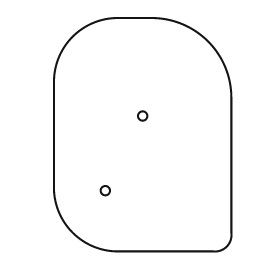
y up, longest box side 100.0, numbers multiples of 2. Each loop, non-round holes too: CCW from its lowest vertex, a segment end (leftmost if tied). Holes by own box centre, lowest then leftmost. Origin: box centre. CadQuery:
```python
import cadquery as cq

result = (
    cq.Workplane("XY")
    .moveTo(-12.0, -50.0)
    .lineTo(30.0, -50.0)
    .threePointArc((36.0, -48.0), (38.0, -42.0))
    .lineTo(38.0, 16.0)
    .threePointArc((28.0, 40.0), (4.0, 50.0))
    .lineTo(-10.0, 50.0)
    .threePointArc((-30.0, 42.0), (-38.0, 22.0))
    .lineTo(-38.0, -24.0)
    .threePointArc((-30.0, -42.0), (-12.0, -50.0))
    .close()
    .moveTo(-16.0, -24.0)
    .circle(2.0)
    .moveTo(0.0, 8.0)
    .circle(2.0)
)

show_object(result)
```